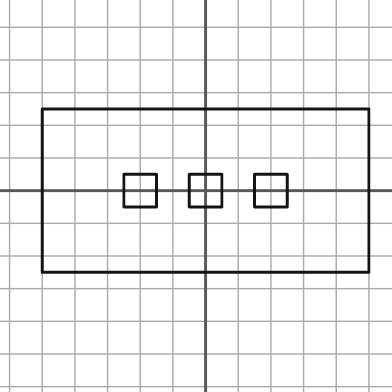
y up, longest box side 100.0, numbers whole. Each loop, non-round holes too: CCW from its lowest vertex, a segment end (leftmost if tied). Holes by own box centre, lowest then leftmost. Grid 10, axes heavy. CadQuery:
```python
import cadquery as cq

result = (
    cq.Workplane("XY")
    .moveTo(-50.0, -25.0)
    .lineTo(50.0, -25.0)
    .lineTo(50.0, 25.0)
    .lineTo(-50.0, 25.0)
    .close()
    .moveTo(-25.0, -5.0)
    .lineTo(-15.0, -5.0)
    .lineTo(-15.0, 5.0)
    .lineTo(-25.0, 5.0)
    .close()
    .moveTo(-5.0, -5.0)
    .lineTo(5.0, -5.0)
    .lineTo(5.0, 5.0)
    .lineTo(-5.0, 5.0)
    .close()
    .moveTo(15.0, -5.0)
    .lineTo(25.0, -5.0)
    .lineTo(25.0, 5.0)
    .lineTo(15.0, 5.0)
    .close()
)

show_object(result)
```